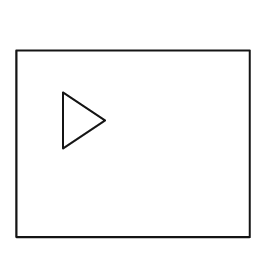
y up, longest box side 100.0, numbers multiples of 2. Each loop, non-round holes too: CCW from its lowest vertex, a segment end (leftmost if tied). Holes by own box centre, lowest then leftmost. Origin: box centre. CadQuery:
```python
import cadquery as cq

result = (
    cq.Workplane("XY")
    .moveTo(-50.0, -40.0)
    .lineTo(50.0, -40.0)
    .lineTo(50.0, 40.0)
    .lineTo(-50.0, 40.0)
    .close()
    .moveTo(-30.0, -2.0)
    .lineTo(-12.0, 10.0)
    .lineTo(-30.0, 22.0)
    .close()
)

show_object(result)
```